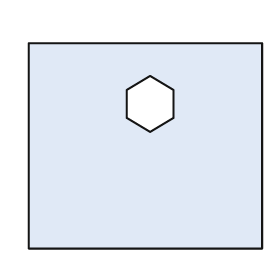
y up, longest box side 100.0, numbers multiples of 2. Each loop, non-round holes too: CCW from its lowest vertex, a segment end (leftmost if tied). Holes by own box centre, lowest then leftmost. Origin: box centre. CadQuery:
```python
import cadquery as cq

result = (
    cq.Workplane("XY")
    .moveTo(-50.0, -44.0)
    .lineTo(50.0, -44.0)
    .lineTo(50.0, 44.0)
    .lineTo(-50.0, 44.0)
    .close()
    .moveTo(2.0, 6.0)
    .lineTo(12.0, 12.0)
    .lineTo(12.0, 24.0)
    .lineTo(2.0, 30.0)
    .lineTo(-8.0, 24.0)
    .lineTo(-8.0, 12.0)
    .close()
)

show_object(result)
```